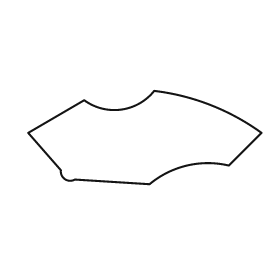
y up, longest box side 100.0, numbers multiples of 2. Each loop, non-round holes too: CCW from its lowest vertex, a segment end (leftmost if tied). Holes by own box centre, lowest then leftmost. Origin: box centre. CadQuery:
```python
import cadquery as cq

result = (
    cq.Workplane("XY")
    .moveTo(2.0, -20.0)
    .threePointArc((18.0, -12.0), (36.0, -12.0))
    .lineTo(50.0, 2.0)
    .threePointArc((28.0, 14.0), (4.0, 20.0))
    .threePointArc((-10.0, 12.0), (-26.0, 16.0))
    .lineTo(-50.0, 2.0)
    .lineTo(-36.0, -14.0)
    .threePointArc((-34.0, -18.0), (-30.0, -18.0))
    .close()
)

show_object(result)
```